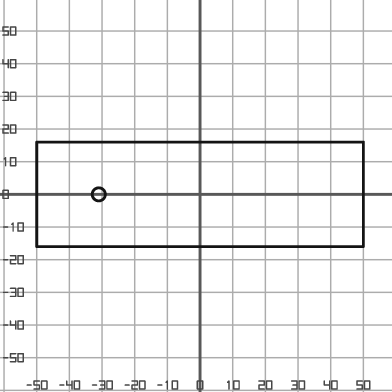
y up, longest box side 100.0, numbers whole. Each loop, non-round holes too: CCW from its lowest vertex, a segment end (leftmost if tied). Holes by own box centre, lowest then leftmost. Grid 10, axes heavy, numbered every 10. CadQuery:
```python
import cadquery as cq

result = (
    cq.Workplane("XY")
    .moveTo(-50.0, -16.0)
    .lineTo(50.0, -16.0)
    .lineTo(50.0, 16.0)
    .lineTo(-50.0, 16.0)
    .close()
    .moveTo(-31.0, 0.0)
    .circle(2.0)
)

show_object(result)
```